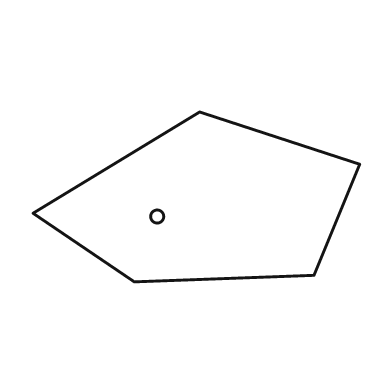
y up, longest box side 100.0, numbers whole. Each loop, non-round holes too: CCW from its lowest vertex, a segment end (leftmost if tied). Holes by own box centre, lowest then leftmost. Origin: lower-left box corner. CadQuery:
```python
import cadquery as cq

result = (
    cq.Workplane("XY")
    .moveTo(31.0, 0.0)
    .lineTo(86.0, 2.0)
    .lineTo(100.0, 36.0)
    .lineTo(51.0, 52.0)
    .lineTo(0.0, 21.0)
    .close()
    .moveTo(38.0, 20.0)
    .circle(2.0)
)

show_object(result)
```